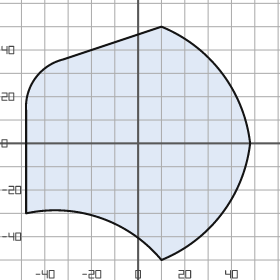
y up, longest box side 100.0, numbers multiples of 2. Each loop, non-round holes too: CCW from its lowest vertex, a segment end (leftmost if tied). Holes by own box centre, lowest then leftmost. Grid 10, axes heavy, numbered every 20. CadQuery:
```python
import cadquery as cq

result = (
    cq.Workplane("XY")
    .moveTo(10.0, -50.0)
    .threePointArc((36.0, -30.0), (48.0, 0.0))
    .threePointArc((36.0, 30.0), (10.0, 50.0))
    .lineTo(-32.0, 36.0)
    .threePointArc((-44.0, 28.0), (-48.0, 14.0))
    .lineTo(-48.0, -30.0)
    .threePointArc((-16.0, -32.0), (10.0, -50.0))
    .close()
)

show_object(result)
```